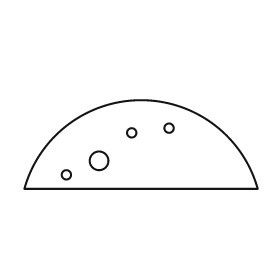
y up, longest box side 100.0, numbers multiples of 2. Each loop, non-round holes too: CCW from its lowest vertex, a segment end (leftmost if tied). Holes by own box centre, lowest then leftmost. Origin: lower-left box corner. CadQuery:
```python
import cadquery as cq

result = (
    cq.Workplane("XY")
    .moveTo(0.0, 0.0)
    .lineTo(100.0, 0.0)
    .threePointArc((50.0, 38.0), (0.0, 0.0))
    .close()
    .moveTo(18.0, 6.0)
    .circle(2.0)
    .moveTo(32.0, 12.0)
    .circle(4.0)
    .moveTo(46.0, 24.0)
    .circle(2.0)
    .moveTo(62.0, 26.0)
    .circle(2.0)
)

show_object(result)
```